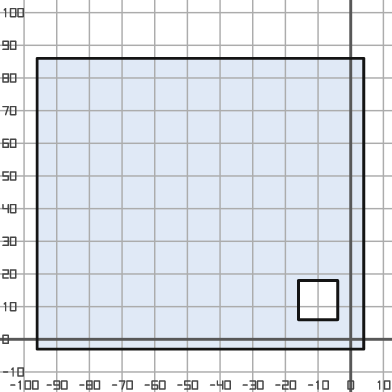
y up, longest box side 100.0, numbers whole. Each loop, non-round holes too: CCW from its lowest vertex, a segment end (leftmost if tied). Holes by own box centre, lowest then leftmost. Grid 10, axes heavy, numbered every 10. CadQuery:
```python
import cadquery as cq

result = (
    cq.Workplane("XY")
    .moveTo(-96.0, -3.0)
    .lineTo(4.0, -3.0)
    .lineTo(4.0, 86.0)
    .lineTo(-96.0, 86.0)
    .close()
    .moveTo(-16.0, 6.0)
    .lineTo(-4.0, 6.0)
    .lineTo(-4.0, 18.0)
    .lineTo(-16.0, 18.0)
    .close()
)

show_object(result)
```